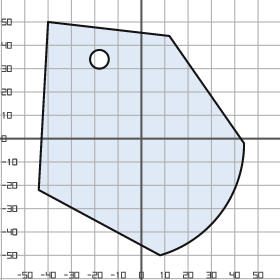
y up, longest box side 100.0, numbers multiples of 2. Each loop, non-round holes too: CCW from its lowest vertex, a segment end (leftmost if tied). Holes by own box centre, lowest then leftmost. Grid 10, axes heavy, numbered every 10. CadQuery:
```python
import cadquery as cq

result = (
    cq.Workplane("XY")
    .moveTo(8.0, -50.0)
    .threePointArc((34.0, -32.0), (44.0, -2.0))
    .lineTo(12.0, 44.0)
    .lineTo(-40.0, 50.0)
    .lineTo(-44.0, -22.0)
    .close()
    .moveTo(-18.0, 34.0)
    .circle(4.0)
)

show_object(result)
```